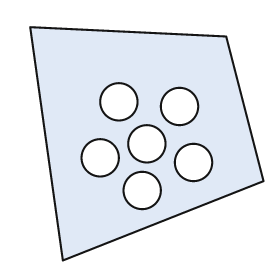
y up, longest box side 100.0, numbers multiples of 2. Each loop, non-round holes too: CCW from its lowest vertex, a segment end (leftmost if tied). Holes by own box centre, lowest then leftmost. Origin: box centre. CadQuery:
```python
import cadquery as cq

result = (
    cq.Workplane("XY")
    .moveTo(-36.0, -50.0)
    .lineTo(50.0, -16.0)
    .lineTo(34.0, 46.0)
    .lineTo(-50.0, 50.0)
    .close()
    .moveTo(-2.0, -20.0)
    .circle(8.0)
    .moveTo(20.0, -8.0)
    .circle(8.0)
    .moveTo(-20.0, -6.0)
    .circle(8.0)
    .moveTo(0.0, 0.0)
    .circle(8.0)
    .moveTo(14.0, 16.0)
    .circle(8.0)
    .moveTo(-12.0, 18.0)
    .circle(8.0)
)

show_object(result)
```